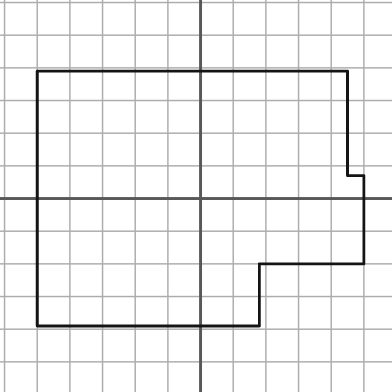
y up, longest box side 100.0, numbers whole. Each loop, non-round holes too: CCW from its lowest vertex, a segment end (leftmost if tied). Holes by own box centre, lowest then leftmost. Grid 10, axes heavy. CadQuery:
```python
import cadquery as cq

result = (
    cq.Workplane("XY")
    .moveTo(-50.0, -39.0)
    .lineTo(18.0, -39.0)
    .lineTo(18.0, -20.0)
    .lineTo(50.0, -20.0)
    .lineTo(50.0, 7.0)
    .lineTo(45.0, 7.0)
    .lineTo(45.0, 39.0)
    .lineTo(-50.0, 39.0)
    .close()
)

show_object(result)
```